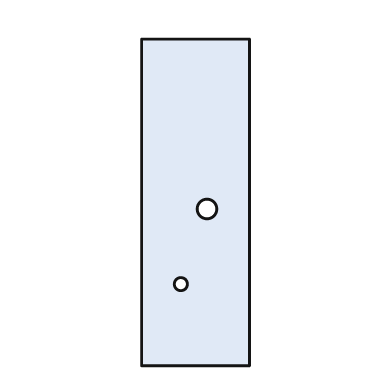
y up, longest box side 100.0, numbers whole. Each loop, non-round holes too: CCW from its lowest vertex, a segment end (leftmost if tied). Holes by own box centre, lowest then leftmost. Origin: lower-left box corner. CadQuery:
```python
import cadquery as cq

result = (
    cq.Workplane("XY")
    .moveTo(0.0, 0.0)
    .lineTo(33.0, 0.0)
    .lineTo(33.0, 100.0)
    .lineTo(0.0, 100.0)
    .close()
    .moveTo(12.0, 25.0)
    .circle(2.0)
    .moveTo(20.0, 48.0)
    .circle(3.0)
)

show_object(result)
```